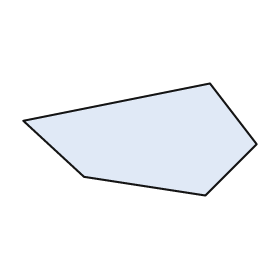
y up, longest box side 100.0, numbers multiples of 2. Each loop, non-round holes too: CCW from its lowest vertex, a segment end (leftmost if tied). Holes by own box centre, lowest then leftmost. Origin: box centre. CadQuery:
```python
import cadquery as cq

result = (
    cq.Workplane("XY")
    .moveTo(28.0, -24.0)
    .lineTo(50.0, -2.0)
    .lineTo(30.0, 24.0)
    .lineTo(-50.0, 8.0)
    .lineTo(-24.0, -16.0)
    .close()
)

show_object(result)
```